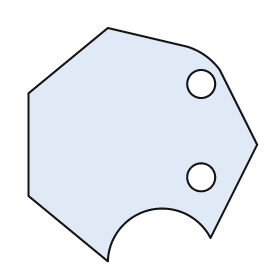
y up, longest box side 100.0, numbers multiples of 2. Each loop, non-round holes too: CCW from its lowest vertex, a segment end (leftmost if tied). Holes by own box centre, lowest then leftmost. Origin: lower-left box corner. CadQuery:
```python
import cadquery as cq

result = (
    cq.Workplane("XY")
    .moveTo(34.0, 0.0)
    .threePointArc((52.0, 22.0), (78.0, 10.0))
    .lineTo(98.0, 50.0)
    .lineTo(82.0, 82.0)
    .threePointArc((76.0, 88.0), (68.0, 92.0))
    .lineTo(34.0, 100.0)
    .lineTo(0.0, 72.0)
    .lineTo(0.0, 28.0)
    .close()
    .moveTo(74.0, 36.0)
    .circle(6.0)
    .moveTo(74.0, 76.0)
    .circle(6.0)
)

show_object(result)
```